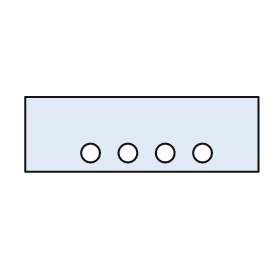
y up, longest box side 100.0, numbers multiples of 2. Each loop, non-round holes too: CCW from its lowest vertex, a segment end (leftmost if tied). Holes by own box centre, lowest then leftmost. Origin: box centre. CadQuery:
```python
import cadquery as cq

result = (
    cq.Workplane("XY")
    .moveTo(-50.0, -16.0)
    .lineTo(50.0, -16.0)
    .lineTo(50.0, 16.0)
    .lineTo(-50.0, 16.0)
    .close()
    .moveTo(-22.0, -8.0)
    .circle(4.0)
    .moveTo(-6.0, -8.0)
    .circle(4.0)
    .moveTo(10.0, -8.0)
    .circle(4.0)
    .moveTo(26.0, -8.0)
    .circle(4.0)
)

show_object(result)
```